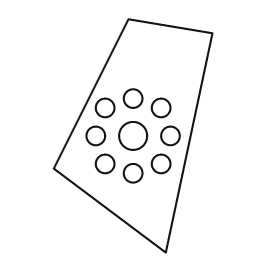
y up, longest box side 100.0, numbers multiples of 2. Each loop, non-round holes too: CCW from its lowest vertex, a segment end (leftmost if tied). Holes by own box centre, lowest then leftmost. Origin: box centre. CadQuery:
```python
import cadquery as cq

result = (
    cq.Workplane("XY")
    .moveTo(14.0, -50.0)
    .lineTo(34.0, 44.0)
    .lineTo(-2.0, 50.0)
    .lineTo(-34.0, -14.0)
    .close()
    .moveTo(0.0, -16.0)
    .circle(4.0)
    .moveTo(-12.0, -12.0)
    .circle(4.0)
    .moveTo(12.0, -12.0)
    .circle(4.0)
    .moveTo(-16.0, 0.0)
    .circle(4.0)
    .moveTo(0.0, 0.0)
    .circle(6.0)
    .moveTo(16.0, 0.0)
    .circle(4.0)
    .moveTo(-12.0, 12.0)
    .circle(4.0)
    .moveTo(12.0, 12.0)
    .circle(4.0)
    .moveTo(0.0, 16.0)
    .circle(4.0)
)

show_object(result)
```